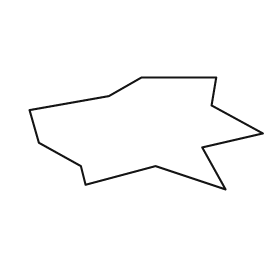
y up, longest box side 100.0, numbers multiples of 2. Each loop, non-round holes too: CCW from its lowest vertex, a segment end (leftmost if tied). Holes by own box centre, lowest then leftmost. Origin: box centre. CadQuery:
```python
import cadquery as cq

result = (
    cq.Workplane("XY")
    .moveTo(34.0, -24.0)
    .lineTo(24.0, -6.0)
    .lineTo(50.0, 0.0)
    .lineTo(28.0, 12.0)
    .lineTo(30.0, 24.0)
    .lineTo(-2.0, 24.0)
    .lineTo(-16.0, 16.0)
    .lineTo(-50.0, 10.0)
    .lineTo(-46.0, -4.0)
    .lineTo(-28.0, -14.0)
    .lineTo(-26.0, -22.0)
    .lineTo(4.0, -14.0)
    .close()
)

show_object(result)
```